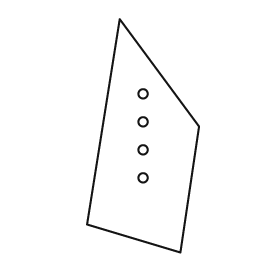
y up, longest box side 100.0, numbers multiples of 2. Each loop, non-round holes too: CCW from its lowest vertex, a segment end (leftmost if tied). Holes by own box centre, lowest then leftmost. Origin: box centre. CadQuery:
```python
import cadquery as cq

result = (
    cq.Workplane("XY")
    .moveTo(16.0, -50.0)
    .lineTo(24.0, 4.0)
    .lineTo(-10.0, 50.0)
    .lineTo(-24.0, -38.0)
    .close()
    .moveTo(0.0, -18.0)
    .circle(2.0)
    .moveTo(0.0, -6.0)
    .circle(2.0)
    .moveTo(0.0, 6.0)
    .circle(2.0)
    .moveTo(0.0, 18.0)
    .circle(2.0)
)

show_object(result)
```